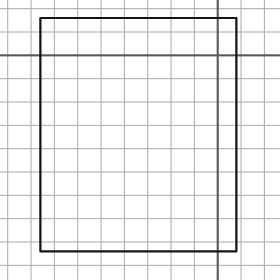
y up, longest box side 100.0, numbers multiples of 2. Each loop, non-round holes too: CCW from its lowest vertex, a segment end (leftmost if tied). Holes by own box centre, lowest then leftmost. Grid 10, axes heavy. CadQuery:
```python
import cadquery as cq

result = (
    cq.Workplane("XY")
    .moveTo(-76.0, -84.0)
    .lineTo(8.0, -84.0)
    .lineTo(8.0, 16.0)
    .lineTo(-76.0, 16.0)
    .close()
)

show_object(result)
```